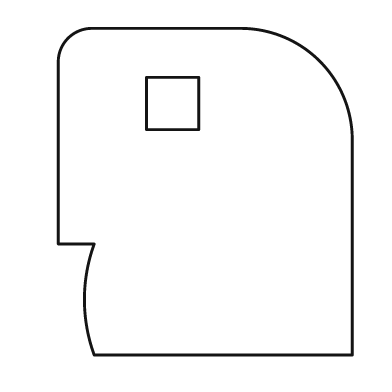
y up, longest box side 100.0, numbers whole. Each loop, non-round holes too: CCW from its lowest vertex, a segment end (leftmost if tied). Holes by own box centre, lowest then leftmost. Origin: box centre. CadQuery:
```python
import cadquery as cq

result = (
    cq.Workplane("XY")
    .moveTo(-34.0, -50.0)
    .lineTo(45.0, -50.0)
    .lineTo(45.0, 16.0)
    .threePointArc((35.0, 40.0), (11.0, 50.0))
    .lineTo(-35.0, 50.0)
    .threePointArc((-42.0, 47.0), (-45.0, 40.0))
    .lineTo(-45.0, -16.0)
    .lineTo(-34.0, -16.0)
    .threePointArc((-37.0, -33.0), (-34.0, -50.0))
    .close()
    .moveTo(-18.0, 19.0)
    .lineTo(-2.0, 19.0)
    .lineTo(-2.0, 35.0)
    .lineTo(-18.0, 35.0)
    .close()
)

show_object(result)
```